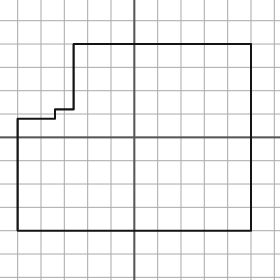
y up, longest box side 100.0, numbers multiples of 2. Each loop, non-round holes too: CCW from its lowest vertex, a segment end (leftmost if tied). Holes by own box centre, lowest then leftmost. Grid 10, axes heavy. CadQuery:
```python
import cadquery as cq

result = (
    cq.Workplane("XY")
    .moveTo(-50.0, -40.0)
    .lineTo(50.0, -40.0)
    .lineTo(50.0, 40.0)
    .lineTo(-26.0, 40.0)
    .lineTo(-26.0, 12.0)
    .lineTo(-34.0, 12.0)
    .lineTo(-34.0, 8.0)
    .lineTo(-50.0, 8.0)
    .close()
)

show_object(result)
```